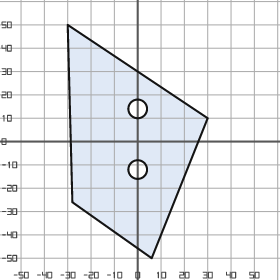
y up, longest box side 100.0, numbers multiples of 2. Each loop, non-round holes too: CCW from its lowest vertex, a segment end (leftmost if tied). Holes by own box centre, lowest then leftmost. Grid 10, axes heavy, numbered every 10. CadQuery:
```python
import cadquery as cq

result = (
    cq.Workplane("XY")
    .moveTo(6.0, -50.0)
    .lineTo(30.0, 10.0)
    .lineTo(-30.0, 50.0)
    .lineTo(-28.0, -26.0)
    .close()
    .moveTo(0.0, -12.0)
    .circle(4.0)
    .moveTo(0.0, 14.0)
    .circle(4.0)
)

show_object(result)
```